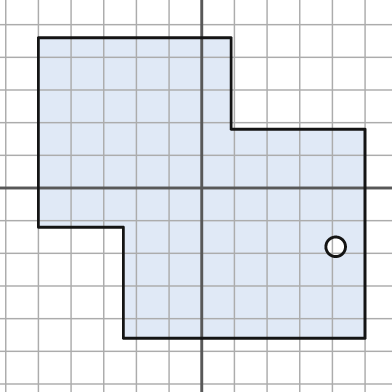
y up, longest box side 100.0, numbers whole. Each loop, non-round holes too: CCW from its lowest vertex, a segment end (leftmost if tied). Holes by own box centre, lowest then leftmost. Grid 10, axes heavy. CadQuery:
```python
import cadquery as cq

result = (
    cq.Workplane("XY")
    .moveTo(-24.0, -46.0)
    .lineTo(50.0, -46.0)
    .lineTo(50.0, 18.0)
    .lineTo(9.0, 18.0)
    .lineTo(9.0, 46.0)
    .lineTo(-50.0, 46.0)
    .lineTo(-50.0, -12.0)
    .lineTo(-24.0, -12.0)
    .close()
    .moveTo(41.0, -18.0)
    .circle(3.0)
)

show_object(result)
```